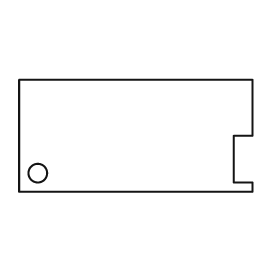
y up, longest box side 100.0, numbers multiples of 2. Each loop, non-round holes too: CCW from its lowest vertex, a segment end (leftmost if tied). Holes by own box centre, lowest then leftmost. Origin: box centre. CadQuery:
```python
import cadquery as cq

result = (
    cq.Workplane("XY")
    .moveTo(-50.0, -24.0)
    .lineTo(50.0, -24.0)
    .lineTo(50.0, -20.0)
    .lineTo(42.0, -20.0)
    .lineTo(42.0, 0.0)
    .lineTo(50.0, 0.0)
    .lineTo(50.0, 24.0)
    .lineTo(-50.0, 24.0)
    .close()
    .moveTo(-42.0, -16.0)
    .circle(4.0)
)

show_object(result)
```